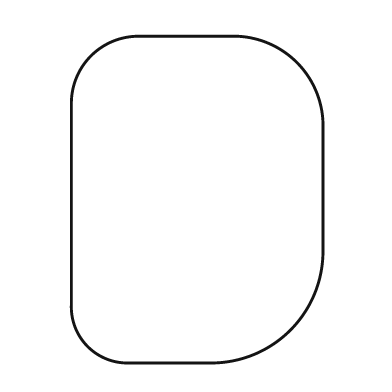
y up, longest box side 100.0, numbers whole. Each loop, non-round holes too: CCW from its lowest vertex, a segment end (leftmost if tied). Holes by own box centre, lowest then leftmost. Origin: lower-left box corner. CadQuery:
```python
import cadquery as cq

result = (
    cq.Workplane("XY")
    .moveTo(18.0, 0.0)
    .lineTo(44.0, 0.0)
    .threePointArc((67.0, 10.0), (77.0, 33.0))
    .lineTo(77.0, 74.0)
    .threePointArc((69.0, 92.0), (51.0, 100.0))
    .lineTo(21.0, 100.0)
    .threePointArc((6.0, 94.0), (0.0, 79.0))
    .lineTo(0.0, 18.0)
    .threePointArc((5.0, 5.0), (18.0, 0.0))
    .close()
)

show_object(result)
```